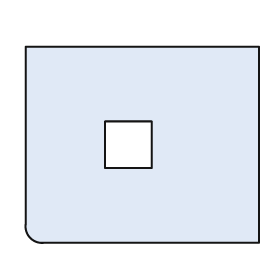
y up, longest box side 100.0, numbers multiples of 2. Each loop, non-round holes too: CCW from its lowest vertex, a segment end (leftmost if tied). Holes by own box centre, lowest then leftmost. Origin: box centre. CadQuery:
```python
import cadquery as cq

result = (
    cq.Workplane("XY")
    .moveTo(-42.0, -42.0)
    .lineTo(50.0, -42.0)
    .lineTo(50.0, 42.0)
    .lineTo(-50.0, 42.0)
    .lineTo(-50.0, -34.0)
    .threePointArc((-48.0, -40.0), (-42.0, -42.0))
    .close()
    .moveTo(-16.0, -10.0)
    .lineTo(4.0, -10.0)
    .lineTo(4.0, 10.0)
    .lineTo(-16.0, 10.0)
    .close()
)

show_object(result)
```